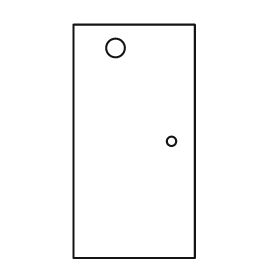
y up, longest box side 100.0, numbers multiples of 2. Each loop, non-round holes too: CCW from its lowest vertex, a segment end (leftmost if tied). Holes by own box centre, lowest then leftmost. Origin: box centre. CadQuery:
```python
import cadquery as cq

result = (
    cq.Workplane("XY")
    .moveTo(-26.0, -50.0)
    .lineTo(26.0, -50.0)
    .lineTo(26.0, 50.0)
    .lineTo(-26.0, 50.0)
    .close()
    .moveTo(16.0, 0.0)
    .circle(2.0)
    .moveTo(-8.0, 40.0)
    .circle(4.0)
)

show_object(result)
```